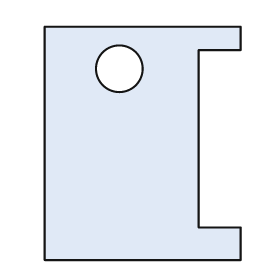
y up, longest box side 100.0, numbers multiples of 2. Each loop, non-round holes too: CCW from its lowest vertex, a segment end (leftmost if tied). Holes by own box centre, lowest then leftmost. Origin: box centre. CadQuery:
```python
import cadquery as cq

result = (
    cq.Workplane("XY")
    .moveTo(-42.0, -50.0)
    .lineTo(42.0, -50.0)
    .lineTo(42.0, -36.0)
    .lineTo(24.0, -36.0)
    .lineTo(24.0, 40.0)
    .lineTo(42.0, 40.0)
    .lineTo(42.0, 50.0)
    .lineTo(-42.0, 50.0)
    .close()
    .moveTo(-10.0, 32.0)
    .circle(10.0)
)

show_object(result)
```